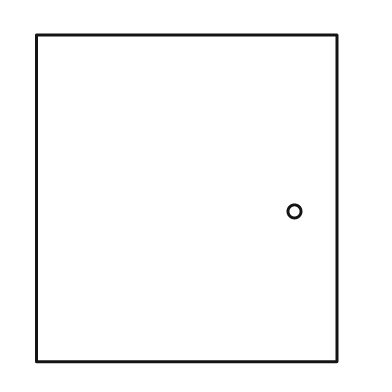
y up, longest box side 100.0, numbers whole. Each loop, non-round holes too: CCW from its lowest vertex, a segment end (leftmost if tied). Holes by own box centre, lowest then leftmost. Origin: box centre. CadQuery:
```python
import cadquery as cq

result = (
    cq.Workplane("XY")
    .moveTo(-46.0, -50.0)
    .lineTo(46.0, -50.0)
    .lineTo(46.0, 50.0)
    .lineTo(-46.0, 50.0)
    .close()
    .moveTo(33.0, -4.0)
    .circle(2.0)
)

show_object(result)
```